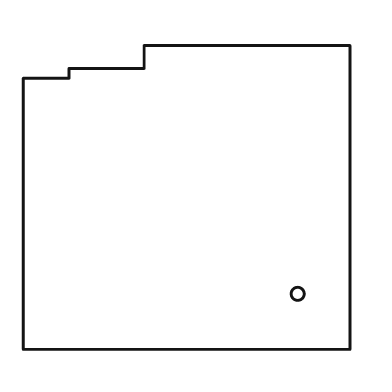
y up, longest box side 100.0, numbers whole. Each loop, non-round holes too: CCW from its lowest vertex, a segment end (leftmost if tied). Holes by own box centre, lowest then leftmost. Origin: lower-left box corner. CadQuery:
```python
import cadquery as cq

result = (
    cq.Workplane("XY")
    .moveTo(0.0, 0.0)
    .lineTo(100.0, 0.0)
    .lineTo(100.0, 93.0)
    .lineTo(37.0, 93.0)
    .lineTo(37.0, 86.0)
    .lineTo(14.0, 86.0)
    .lineTo(14.0, 83.0)
    .lineTo(0.0, 83.0)
    .close()
    .moveTo(84.0, 17.0)
    .circle(2.0)
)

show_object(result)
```